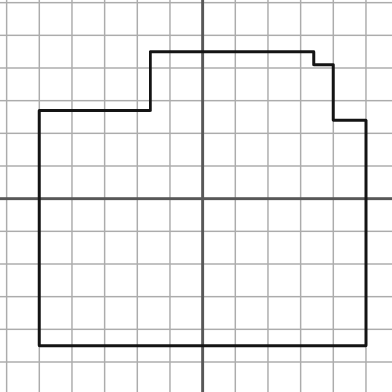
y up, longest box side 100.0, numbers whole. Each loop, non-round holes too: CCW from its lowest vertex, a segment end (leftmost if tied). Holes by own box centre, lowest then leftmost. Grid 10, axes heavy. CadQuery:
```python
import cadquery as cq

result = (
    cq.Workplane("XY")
    .moveTo(-50.0, -45.0)
    .lineTo(50.0, -45.0)
    .lineTo(50.0, 24.0)
    .lineTo(40.0, 24.0)
    .lineTo(40.0, 41.0)
    .lineTo(34.0, 41.0)
    .lineTo(34.0, 45.0)
    .lineTo(-16.0, 45.0)
    .lineTo(-16.0, 27.0)
    .lineTo(-50.0, 27.0)
    .close()
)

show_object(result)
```